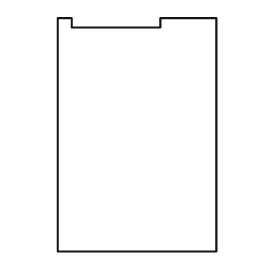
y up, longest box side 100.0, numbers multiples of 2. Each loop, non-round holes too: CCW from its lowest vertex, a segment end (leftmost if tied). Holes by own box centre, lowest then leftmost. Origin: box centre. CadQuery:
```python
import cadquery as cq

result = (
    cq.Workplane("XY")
    .moveTo(-34.0, -50.0)
    .lineTo(34.0, -50.0)
    .lineTo(34.0, 50.0)
    .lineTo(10.0, 50.0)
    .lineTo(10.0, 46.0)
    .lineTo(-28.0, 46.0)
    .lineTo(-28.0, 50.0)
    .lineTo(-34.0, 50.0)
    .close()
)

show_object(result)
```